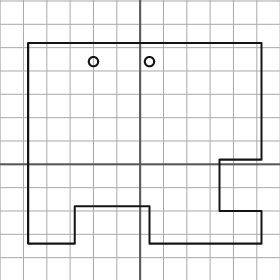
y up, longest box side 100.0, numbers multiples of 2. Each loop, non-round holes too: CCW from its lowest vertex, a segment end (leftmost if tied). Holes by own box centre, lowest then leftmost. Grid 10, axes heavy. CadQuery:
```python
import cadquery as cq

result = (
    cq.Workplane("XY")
    .moveTo(-48.0, -34.0)
    .lineTo(-28.0, -34.0)
    .lineTo(-28.0, -18.0)
    .lineTo(4.0, -18.0)
    .lineTo(4.0, -34.0)
    .lineTo(52.0, -34.0)
    .lineTo(52.0, -20.0)
    .lineTo(34.0, -20.0)
    .lineTo(34.0, 2.0)
    .lineTo(52.0, 2.0)
    .lineTo(52.0, 52.0)
    .lineTo(-48.0, 52.0)
    .close()
    .moveTo(-20.0, 44.0)
    .circle(2.0)
    .moveTo(4.0, 44.0)
    .circle(2.0)
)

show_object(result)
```